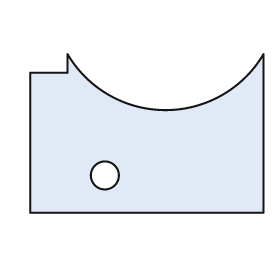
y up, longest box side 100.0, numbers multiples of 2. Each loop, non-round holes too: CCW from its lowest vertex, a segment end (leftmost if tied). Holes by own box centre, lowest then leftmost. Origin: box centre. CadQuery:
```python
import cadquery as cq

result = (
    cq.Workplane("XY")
    .moveTo(-50.0, -34.0)
    .lineTo(50.0, -34.0)
    .lineTo(50.0, 34.0)
    .threePointArc((8.0, 10.0), (-34.0, 34.0))
    .lineTo(-34.0, 26.0)
    .lineTo(-50.0, 26.0)
    .close()
    .moveTo(-18.0, -18.0)
    .circle(6.0)
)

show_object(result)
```